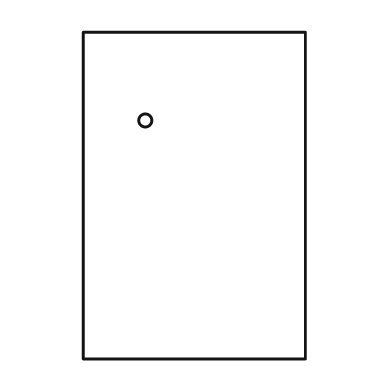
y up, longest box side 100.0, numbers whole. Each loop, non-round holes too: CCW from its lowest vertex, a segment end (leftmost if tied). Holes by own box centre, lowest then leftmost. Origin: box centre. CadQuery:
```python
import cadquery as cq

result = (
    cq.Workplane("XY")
    .moveTo(-34.0, -50.0)
    .lineTo(34.0, -50.0)
    .lineTo(34.0, 50.0)
    .lineTo(-34.0, 50.0)
    .close()
    .moveTo(-15.0, 23.0)
    .circle(2.0)
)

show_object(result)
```